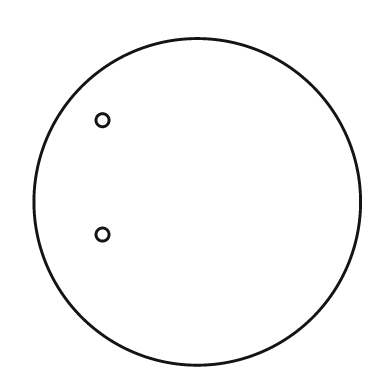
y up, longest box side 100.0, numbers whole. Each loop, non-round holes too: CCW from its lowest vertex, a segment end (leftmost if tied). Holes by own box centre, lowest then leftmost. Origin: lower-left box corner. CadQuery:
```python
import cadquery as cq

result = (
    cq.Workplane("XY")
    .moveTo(50.0, 50.0)
    .circle(50.0)
    .moveTo(21.0, 40.0)
    .circle(2.0)
    .moveTo(21.0, 75.0)
    .circle(2.0)
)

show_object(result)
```